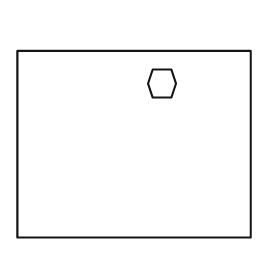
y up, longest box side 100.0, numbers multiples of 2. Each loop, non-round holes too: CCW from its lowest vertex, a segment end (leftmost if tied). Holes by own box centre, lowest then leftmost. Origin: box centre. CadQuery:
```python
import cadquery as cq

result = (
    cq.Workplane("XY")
    .moveTo(-50.0, -40.0)
    .lineTo(50.0, -40.0)
    .lineTo(50.0, 40.0)
    .lineTo(-50.0, 40.0)
    .close()
    .moveTo(8.0, 20.0)
    .lineTo(16.0, 20.0)
    .lineTo(18.0, 26.0)
    .lineTo(16.0, 32.0)
    .lineTo(8.0, 32.0)
    .lineTo(6.0, 26.0)
    .close()
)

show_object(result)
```